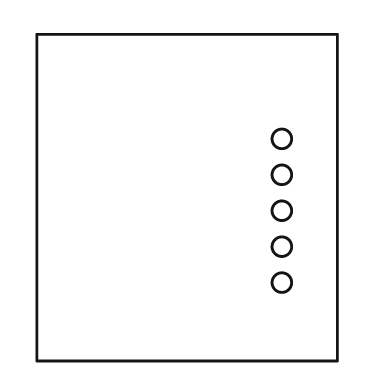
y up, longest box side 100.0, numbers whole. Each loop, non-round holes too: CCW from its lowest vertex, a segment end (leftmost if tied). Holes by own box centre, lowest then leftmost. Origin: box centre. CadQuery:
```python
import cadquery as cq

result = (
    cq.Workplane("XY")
    .moveTo(-46.0, -50.0)
    .lineTo(46.0, -50.0)
    .lineTo(46.0, 50.0)
    .lineTo(-46.0, 50.0)
    .close()
    .moveTo(29.0, -26.0)
    .circle(3.0)
    .moveTo(29.0, -15.0)
    .circle(3.0)
    .moveTo(29.0, -4.0)
    .circle(3.0)
    .moveTo(29.0, 7.0)
    .circle(3.0)
    .moveTo(29.0, 18.0)
    .circle(3.0)
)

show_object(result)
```